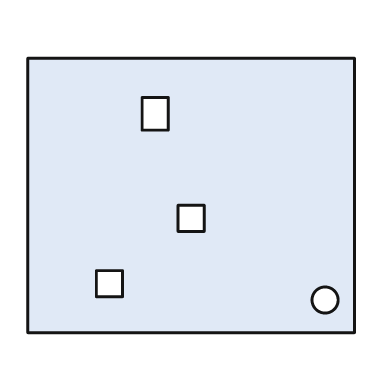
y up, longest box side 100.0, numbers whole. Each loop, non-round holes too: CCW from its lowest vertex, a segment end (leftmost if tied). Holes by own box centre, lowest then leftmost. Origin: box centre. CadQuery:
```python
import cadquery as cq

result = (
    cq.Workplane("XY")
    .moveTo(-50.0, -42.0)
    .lineTo(50.0, -42.0)
    .lineTo(50.0, 42.0)
    .lineTo(-50.0, 42.0)
    .close()
    .moveTo(41.0, -32.0)
    .circle(4.0)
    .moveTo(-29.0, -31.0)
    .lineTo(-21.0, -31.0)
    .lineTo(-21.0, -23.0)
    .lineTo(-29.0, -23.0)
    .close()
    .moveTo(-4.0, -11.0)
    .lineTo(4.0, -11.0)
    .lineTo(4.0, -3.0)
    .lineTo(-4.0, -3.0)
    .close()
    .moveTo(-15.0, 20.0)
    .lineTo(-7.0, 20.0)
    .lineTo(-7.0, 30.0)
    .lineTo(-15.0, 30.0)
    .close()
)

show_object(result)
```